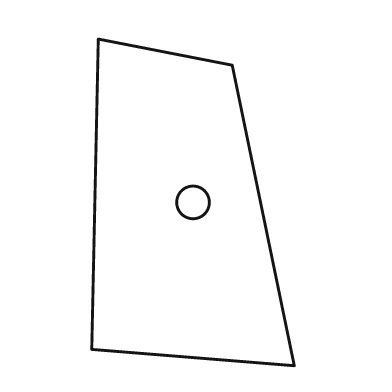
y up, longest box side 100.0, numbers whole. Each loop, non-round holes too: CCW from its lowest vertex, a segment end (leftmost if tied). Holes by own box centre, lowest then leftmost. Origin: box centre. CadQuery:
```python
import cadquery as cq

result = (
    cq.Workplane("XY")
    .moveTo(31.0, -50.0)
    .lineTo(12.0, 42.0)
    .lineTo(-29.0, 50.0)
    .lineTo(-31.0, -45.0)
    .close()
    .moveTo(0.0, 0.0)
    .circle(5.0)
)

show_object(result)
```